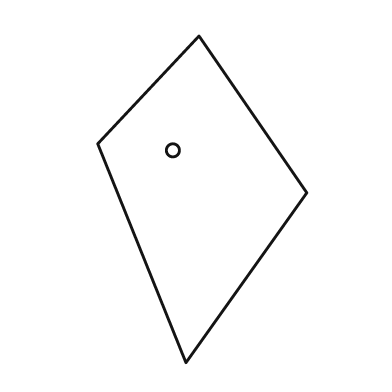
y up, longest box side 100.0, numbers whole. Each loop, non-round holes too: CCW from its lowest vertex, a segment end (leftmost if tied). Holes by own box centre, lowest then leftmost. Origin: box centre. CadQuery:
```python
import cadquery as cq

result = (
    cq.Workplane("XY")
    .moveTo(-5.0, -50.0)
    .lineTo(32.0, 2.0)
    .lineTo(-1.0, 50.0)
    .lineTo(-32.0, 17.0)
    .close()
    .moveTo(-9.0, 15.0)
    .circle(2.0)
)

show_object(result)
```